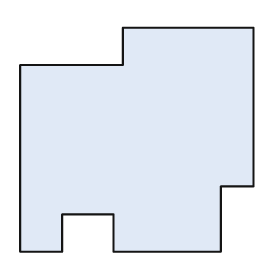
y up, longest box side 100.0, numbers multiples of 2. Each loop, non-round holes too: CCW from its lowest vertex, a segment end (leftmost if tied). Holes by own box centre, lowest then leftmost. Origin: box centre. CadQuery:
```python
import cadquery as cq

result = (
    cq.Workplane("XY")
    .moveTo(-50.0, -48.0)
    .lineTo(-32.0, -48.0)
    .lineTo(-32.0, -32.0)
    .lineTo(-10.0, -32.0)
    .lineTo(-10.0, -48.0)
    .lineTo(36.0, -48.0)
    .lineTo(36.0, -20.0)
    .lineTo(50.0, -20.0)
    .lineTo(50.0, 48.0)
    .lineTo(-6.0, 48.0)
    .lineTo(-6.0, 32.0)
    .lineTo(-50.0, 32.0)
    .close()
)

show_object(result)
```